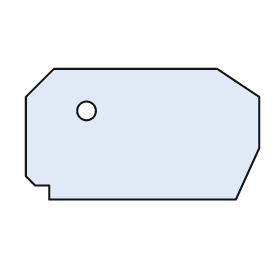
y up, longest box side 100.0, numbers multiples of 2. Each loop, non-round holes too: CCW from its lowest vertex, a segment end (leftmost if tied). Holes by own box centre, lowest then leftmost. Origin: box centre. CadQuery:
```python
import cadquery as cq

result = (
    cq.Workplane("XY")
    .moveTo(-40.0, -28.0)
    .lineTo(40.0, -28.0)
    .lineTo(50.0, -6.0)
    .lineTo(50.0, 16.0)
    .lineTo(32.0, 28.0)
    .lineTo(-38.0, 28.0)
    .lineTo(-50.0, 16.0)
    .lineTo(-50.0, -18.0)
    .lineTo(-46.0, -22.0)
    .lineTo(-40.0, -22.0)
    .close()
    .moveTo(-24.0, 10.0)
    .circle(4.0)
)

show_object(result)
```